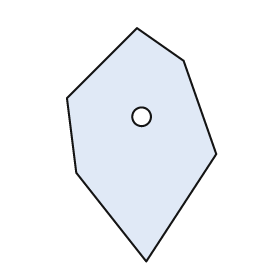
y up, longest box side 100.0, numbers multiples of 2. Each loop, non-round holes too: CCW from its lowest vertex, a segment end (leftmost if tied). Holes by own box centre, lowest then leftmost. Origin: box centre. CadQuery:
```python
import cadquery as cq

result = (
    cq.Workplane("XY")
    .moveTo(2.0, -50.0)
    .lineTo(32.0, -4.0)
    .lineTo(18.0, 36.0)
    .lineTo(-2.0, 50.0)
    .lineTo(-32.0, 20.0)
    .lineTo(-28.0, -12.0)
    .close()
    .moveTo(0.0, 12.0)
    .circle(4.0)
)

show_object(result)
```